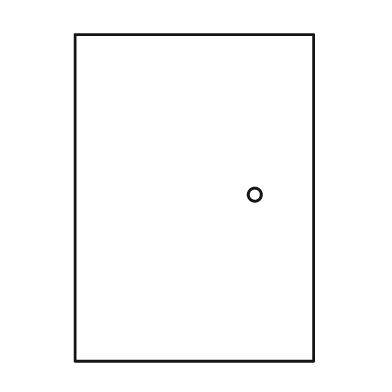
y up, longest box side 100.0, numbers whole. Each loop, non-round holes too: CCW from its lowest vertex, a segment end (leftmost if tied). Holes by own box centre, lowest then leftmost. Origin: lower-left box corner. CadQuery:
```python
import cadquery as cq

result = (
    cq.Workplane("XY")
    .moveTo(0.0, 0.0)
    .lineTo(73.0, 0.0)
    .lineTo(73.0, 100.0)
    .lineTo(0.0, 100.0)
    .close()
    .moveTo(55.0, 51.0)
    .circle(2.0)
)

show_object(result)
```